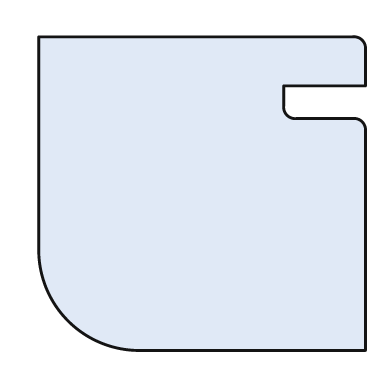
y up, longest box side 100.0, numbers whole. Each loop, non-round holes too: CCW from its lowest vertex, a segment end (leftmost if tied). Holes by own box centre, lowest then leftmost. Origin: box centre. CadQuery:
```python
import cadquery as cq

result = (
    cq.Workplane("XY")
    .moveTo(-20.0, -48.0)
    .lineTo(50.0, -48.0)
    .lineTo(50.0, 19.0)
    .threePointArc((49.0, 22.0), (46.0, 23.0))
    .lineTo(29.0, 23.0)
    .threePointArc((26.0, 24.0), (25.0, 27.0))
    .lineTo(25.0, 33.0)
    .lineTo(50.0, 33.0)
    .lineTo(50.0, 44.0)
    .threePointArc((49.0, 47.0), (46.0, 48.0))
    .lineTo(-50.0, 48.0)
    .lineTo(-50.0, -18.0)
    .threePointArc((-41.0, -39.0), (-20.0, -48.0))
    .close()
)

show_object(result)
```